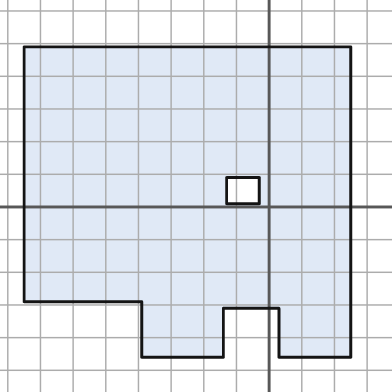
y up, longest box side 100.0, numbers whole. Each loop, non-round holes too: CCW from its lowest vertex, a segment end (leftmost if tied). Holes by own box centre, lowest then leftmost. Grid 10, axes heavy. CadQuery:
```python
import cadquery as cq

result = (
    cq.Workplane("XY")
    .moveTo(-39.0, -46.0)
    .lineTo(-14.0, -46.0)
    .lineTo(-14.0, -31.0)
    .lineTo(3.0, -31.0)
    .lineTo(3.0, -46.0)
    .lineTo(25.0, -46.0)
    .lineTo(25.0, 49.0)
    .lineTo(-75.0, 49.0)
    .lineTo(-75.0, -29.0)
    .lineTo(-39.0, -29.0)
    .close()
    .moveTo(-13.0, 1.0)
    .lineTo(-3.0, 1.0)
    .lineTo(-3.0, 9.0)
    .lineTo(-13.0, 9.0)
    .close()
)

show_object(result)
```